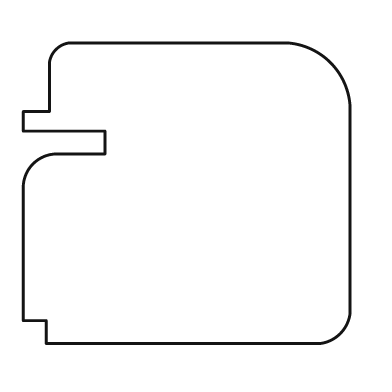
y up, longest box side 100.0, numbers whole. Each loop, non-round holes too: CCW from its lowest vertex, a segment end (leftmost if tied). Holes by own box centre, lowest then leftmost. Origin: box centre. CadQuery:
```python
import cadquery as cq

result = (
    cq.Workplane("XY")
    .moveTo(-43.0, -46.0)
    .lineTo(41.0, -46.0)
    .threePointArc((47.0, -43.0), (50.0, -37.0))
    .lineTo(50.0, 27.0)
    .threePointArc((44.0, 40.0), (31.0, 46.0))
    .lineTo(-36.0, 46.0)
    .threePointArc((-40.0, 44.0), (-42.0, 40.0))
    .lineTo(-42.0, 25.0)
    .lineTo(-50.0, 25.0)
    .lineTo(-50.0, 19.0)
    .lineTo(-25.0, 19.0)
    .lineTo(-25.0, 12.0)
    .lineTo(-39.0, 12.0)
    .threePointArc((-47.0, 9.0), (-50.0, 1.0))
    .lineTo(-50.0, -39.0)
    .lineTo(-43.0, -39.0)
    .close()
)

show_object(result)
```